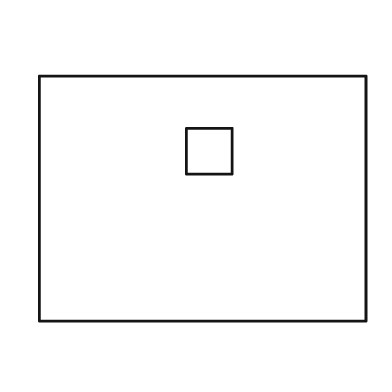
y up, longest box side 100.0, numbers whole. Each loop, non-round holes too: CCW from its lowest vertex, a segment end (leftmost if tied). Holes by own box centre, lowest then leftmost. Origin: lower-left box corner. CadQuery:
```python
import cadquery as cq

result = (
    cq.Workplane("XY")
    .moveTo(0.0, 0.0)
    .lineTo(100.0, 0.0)
    .lineTo(100.0, 75.0)
    .lineTo(0.0, 75.0)
    .close()
    .moveTo(45.0, 45.0)
    .lineTo(59.0, 45.0)
    .lineTo(59.0, 59.0)
    .lineTo(45.0, 59.0)
    .close()
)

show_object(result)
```